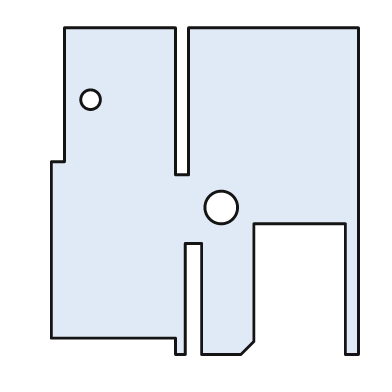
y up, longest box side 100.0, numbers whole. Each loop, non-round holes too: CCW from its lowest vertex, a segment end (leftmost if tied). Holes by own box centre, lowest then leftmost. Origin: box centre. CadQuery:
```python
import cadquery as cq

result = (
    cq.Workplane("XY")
    .moveTo(-9.0, -50.0)
    .lineTo(-6.0, -50.0)
    .lineTo(-6.0, -16.0)
    .lineTo(-1.0, -16.0)
    .lineTo(-1.0, -50.0)
    .lineTo(11.0, -50.0)
    .lineTo(15.0, -46.0)
    .lineTo(15.0, -10.0)
    .lineTo(43.0, -10.0)
    .lineTo(43.0, -50.0)
    .lineTo(47.0, -50.0)
    .lineTo(47.0, 50.0)
    .lineTo(-5.0, 50.0)
    .lineTo(-5.0, 5.0)
    .lineTo(-9.0, 5.0)
    .lineTo(-9.0, 50.0)
    .lineTo(-43.0, 50.0)
    .lineTo(-43.0, 9.0)
    .lineTo(-47.0, 9.0)
    .lineTo(-47.0, -45.0)
    .lineTo(-9.0, -45.0)
    .close()
    .moveTo(5.0, -5.0)
    .circle(5.0)
    .moveTo(-35.0, 28.0)
    .circle(3.0)
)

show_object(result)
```